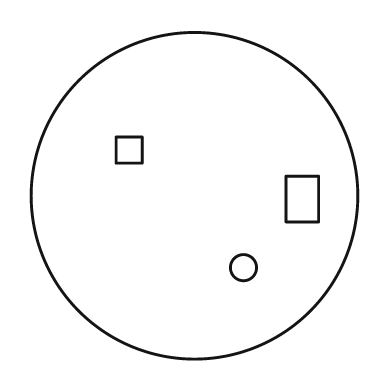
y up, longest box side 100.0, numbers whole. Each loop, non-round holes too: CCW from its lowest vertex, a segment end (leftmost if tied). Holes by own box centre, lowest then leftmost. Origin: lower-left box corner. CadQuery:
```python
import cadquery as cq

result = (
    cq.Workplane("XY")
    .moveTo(50.0, 50.0)
    .circle(50.0)
    .moveTo(65.0, 28.0)
    .circle(4.0)
    .moveTo(78.0, 42.0)
    .lineTo(88.0, 42.0)
    .lineTo(88.0, 56.0)
    .lineTo(78.0, 56.0)
    .close()
    .moveTo(26.0, 60.0)
    .lineTo(34.0, 60.0)
    .lineTo(34.0, 68.0)
    .lineTo(26.0, 68.0)
    .close()
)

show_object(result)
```